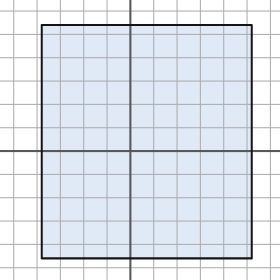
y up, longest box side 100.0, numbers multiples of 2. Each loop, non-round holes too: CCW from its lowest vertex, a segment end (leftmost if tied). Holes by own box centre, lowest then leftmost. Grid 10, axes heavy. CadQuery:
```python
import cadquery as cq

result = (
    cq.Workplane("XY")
    .moveTo(-38.0, -46.0)
    .lineTo(52.0, -46.0)
    .lineTo(52.0, 54.0)
    .lineTo(-38.0, 54.0)
    .close()
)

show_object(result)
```